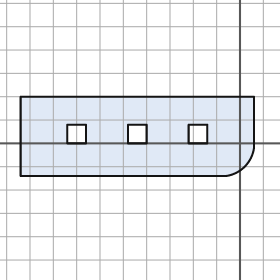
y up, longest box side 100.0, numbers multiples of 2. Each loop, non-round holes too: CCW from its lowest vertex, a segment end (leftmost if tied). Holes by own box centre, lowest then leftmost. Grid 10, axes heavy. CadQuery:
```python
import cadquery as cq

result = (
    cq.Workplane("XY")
    .moveTo(-94.0, -14.0)
    .lineTo(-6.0, -14.0)
    .threePointArc((2.0, -10.0), (6.0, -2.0))
    .lineTo(6.0, 20.0)
    .lineTo(-94.0, 20.0)
    .close()
    .moveTo(-74.0, 0.0)
    .lineTo(-66.0, 0.0)
    .lineTo(-66.0, 8.0)
    .lineTo(-74.0, 8.0)
    .close()
    .moveTo(-48.0, 0.0)
    .lineTo(-40.0, 0.0)
    .lineTo(-40.0, 8.0)
    .lineTo(-48.0, 8.0)
    .close()
    .moveTo(-22.0, 0.0)
    .lineTo(-14.0, 0.0)
    .lineTo(-14.0, 8.0)
    .lineTo(-22.0, 8.0)
    .close()
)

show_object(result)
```